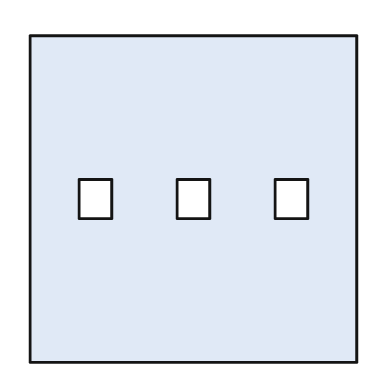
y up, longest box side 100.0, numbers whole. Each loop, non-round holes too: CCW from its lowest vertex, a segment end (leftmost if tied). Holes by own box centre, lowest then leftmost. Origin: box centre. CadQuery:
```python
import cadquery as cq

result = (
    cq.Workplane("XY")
    .moveTo(-50.0, -50.0)
    .lineTo(50.0, -50.0)
    .lineTo(50.0, 50.0)
    .lineTo(-50.0, 50.0)
    .close()
    .moveTo(-35.0, -6.0)
    .lineTo(-25.0, -6.0)
    .lineTo(-25.0, 6.0)
    .lineTo(-35.0, 6.0)
    .close()
    .moveTo(-5.0, -6.0)
    .lineTo(5.0, -6.0)
    .lineTo(5.0, 6.0)
    .lineTo(-5.0, 6.0)
    .close()
    .moveTo(25.0, -6.0)
    .lineTo(35.0, -6.0)
    .lineTo(35.0, 6.0)
    .lineTo(25.0, 6.0)
    .close()
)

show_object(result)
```